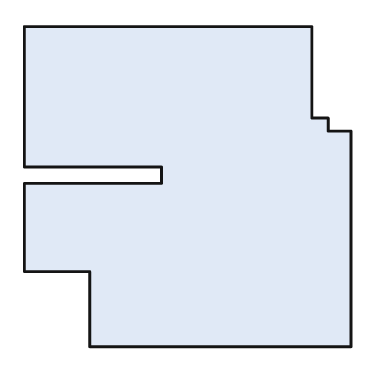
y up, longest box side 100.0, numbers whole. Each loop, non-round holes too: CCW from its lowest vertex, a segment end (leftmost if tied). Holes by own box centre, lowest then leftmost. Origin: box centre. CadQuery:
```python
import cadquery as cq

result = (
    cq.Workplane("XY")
    .moveTo(-30.0, -49.0)
    .lineTo(50.0, -49.0)
    .lineTo(50.0, 17.0)
    .lineTo(43.0, 17.0)
    .lineTo(43.0, 21.0)
    .lineTo(38.0, 21.0)
    .lineTo(38.0, 49.0)
    .lineTo(-50.0, 49.0)
    .lineTo(-50.0, 6.0)
    .lineTo(-8.0, 6.0)
    .lineTo(-8.0, 1.0)
    .lineTo(-50.0, 1.0)
    .lineTo(-50.0, -26.0)
    .lineTo(-30.0, -26.0)
    .close()
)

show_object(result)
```